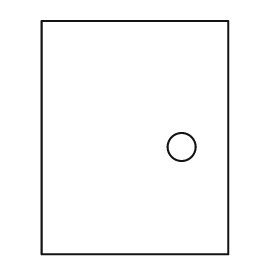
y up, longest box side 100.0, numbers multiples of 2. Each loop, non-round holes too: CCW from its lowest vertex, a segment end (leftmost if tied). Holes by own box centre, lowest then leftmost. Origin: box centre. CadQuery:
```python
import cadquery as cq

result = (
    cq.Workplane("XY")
    .moveTo(-40.0, -50.0)
    .lineTo(40.0, -50.0)
    .lineTo(40.0, 50.0)
    .lineTo(-40.0, 50.0)
    .close()
    .moveTo(20.0, -4.0)
    .circle(6.0)
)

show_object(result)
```